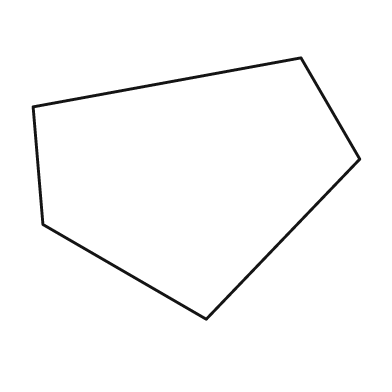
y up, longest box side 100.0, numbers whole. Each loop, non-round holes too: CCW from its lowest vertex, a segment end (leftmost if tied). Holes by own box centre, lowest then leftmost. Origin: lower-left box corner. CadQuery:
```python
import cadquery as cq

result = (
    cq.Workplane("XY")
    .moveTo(53.0, 0.0)
    .lineTo(100.0, 49.0)
    .lineTo(82.0, 80.0)
    .lineTo(0.0, 65.0)
    .lineTo(3.0, 29.0)
    .close()
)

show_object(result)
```